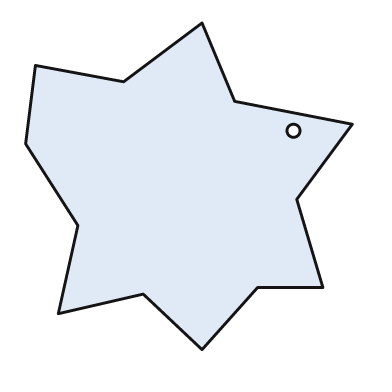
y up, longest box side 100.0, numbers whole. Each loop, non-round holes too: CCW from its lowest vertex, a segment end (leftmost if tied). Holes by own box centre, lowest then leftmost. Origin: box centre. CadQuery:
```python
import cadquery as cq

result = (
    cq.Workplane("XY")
    .moveTo(4.0, -50.0)
    .lineTo(21.0, -31.0)
    .lineTo(41.0, -31.0)
    .lineTo(33.0, -4.0)
    .lineTo(50.0, 19.0)
    .lineTo(14.0, 26.0)
    .lineTo(4.0, 50.0)
    .lineTo(-20.0, 32.0)
    .lineTo(-47.0, 37.0)
    .lineTo(-50.0, 13.0)
    .lineTo(-34.0, -12.0)
    .lineTo(-40.0, -39.0)
    .lineTo(-14.0, -33.0)
    .close()
    .moveTo(32.0, 17.0)
    .circle(2.0)
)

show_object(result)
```